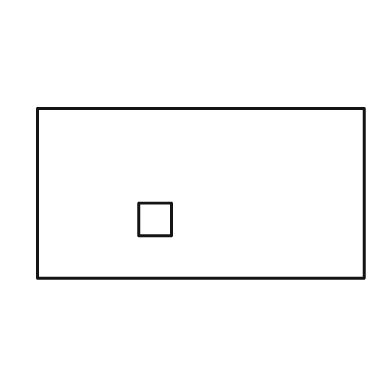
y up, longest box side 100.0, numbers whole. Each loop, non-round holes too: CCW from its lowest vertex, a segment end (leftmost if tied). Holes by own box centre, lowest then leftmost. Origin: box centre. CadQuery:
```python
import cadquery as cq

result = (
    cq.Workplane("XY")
    .moveTo(-50.0, -26.0)
    .lineTo(50.0, -26.0)
    .lineTo(50.0, 26.0)
    .lineTo(-50.0, 26.0)
    .close()
    .moveTo(-19.0, -13.0)
    .lineTo(-9.0, -13.0)
    .lineTo(-9.0, -3.0)
    .lineTo(-19.0, -3.0)
    .close()
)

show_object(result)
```